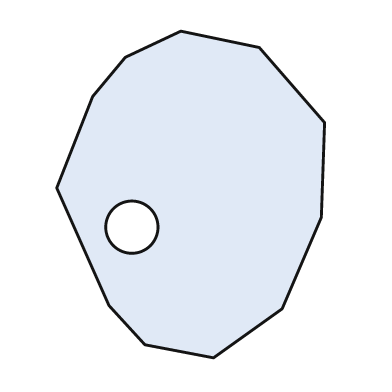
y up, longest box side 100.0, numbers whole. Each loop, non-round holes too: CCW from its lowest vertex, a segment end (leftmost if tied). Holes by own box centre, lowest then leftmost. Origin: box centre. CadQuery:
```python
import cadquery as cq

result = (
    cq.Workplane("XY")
    .moveTo(7.0, -50.0)
    .lineTo(28.0, -35.0)
    .lineTo(40.0, -7.0)
    .lineTo(41.0, 22.0)
    .lineTo(21.0, 45.0)
    .lineTo(-3.0, 50.0)
    .lineTo(-20.0, 42.0)
    .lineTo(-30.0, 30.0)
    .lineTo(-41.0, 2.0)
    .lineTo(-25.0, -34.0)
    .lineTo(-14.0, -46.0)
    .close()
    .moveTo(-18.0, -10.0)
    .circle(8.0)
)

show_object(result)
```